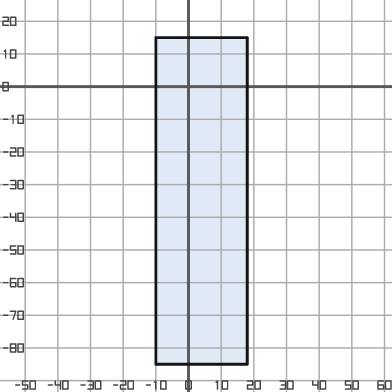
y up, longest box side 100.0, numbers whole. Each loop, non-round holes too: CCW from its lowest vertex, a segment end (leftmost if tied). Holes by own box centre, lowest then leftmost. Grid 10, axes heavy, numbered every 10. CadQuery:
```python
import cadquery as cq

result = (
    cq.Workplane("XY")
    .moveTo(-10.0, -85.0)
    .lineTo(18.0, -85.0)
    .lineTo(18.0, 15.0)
    .lineTo(-10.0, 15.0)
    .close()
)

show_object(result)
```